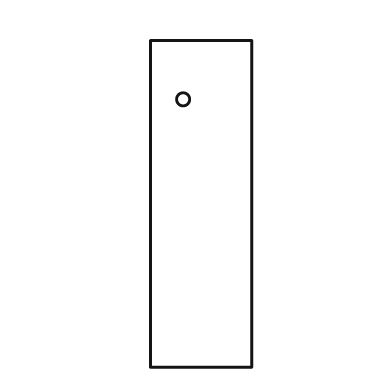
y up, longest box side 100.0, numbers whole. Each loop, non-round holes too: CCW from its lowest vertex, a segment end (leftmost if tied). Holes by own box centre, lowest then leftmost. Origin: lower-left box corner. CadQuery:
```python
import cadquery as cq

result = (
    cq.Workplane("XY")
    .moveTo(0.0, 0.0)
    .lineTo(31.0, 0.0)
    .lineTo(31.0, 100.0)
    .lineTo(0.0, 100.0)
    .close()
    .moveTo(10.0, 82.0)
    .circle(2.0)
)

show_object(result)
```